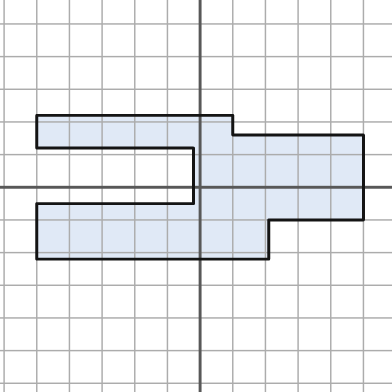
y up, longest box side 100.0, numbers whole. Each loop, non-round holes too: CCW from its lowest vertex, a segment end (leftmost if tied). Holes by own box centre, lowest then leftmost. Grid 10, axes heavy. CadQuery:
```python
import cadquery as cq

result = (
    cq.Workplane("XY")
    .moveTo(-50.0, -22.0)
    .lineTo(21.0, -22.0)
    .lineTo(21.0, -10.0)
    .lineTo(50.0, -10.0)
    .lineTo(50.0, 16.0)
    .lineTo(10.0, 16.0)
    .lineTo(10.0, 22.0)
    .lineTo(-50.0, 22.0)
    .lineTo(-50.0, 12.0)
    .lineTo(-2.0, 12.0)
    .lineTo(-2.0, -5.0)
    .lineTo(-50.0, -5.0)
    .close()
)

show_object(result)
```